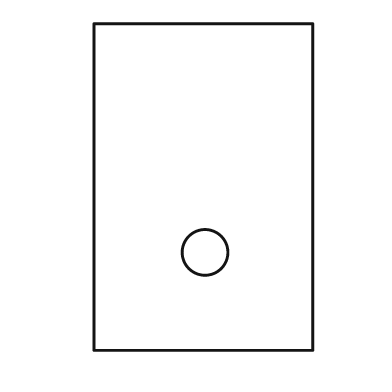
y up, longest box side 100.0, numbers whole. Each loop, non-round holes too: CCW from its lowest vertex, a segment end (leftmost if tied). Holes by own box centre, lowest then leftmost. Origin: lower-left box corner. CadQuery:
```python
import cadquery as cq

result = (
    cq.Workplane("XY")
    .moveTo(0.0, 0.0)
    .lineTo(67.0, 0.0)
    .lineTo(67.0, 100.0)
    .lineTo(0.0, 100.0)
    .close()
    .moveTo(34.0, 30.0)
    .circle(7.0)
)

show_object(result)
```